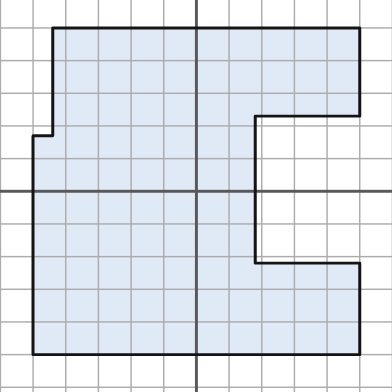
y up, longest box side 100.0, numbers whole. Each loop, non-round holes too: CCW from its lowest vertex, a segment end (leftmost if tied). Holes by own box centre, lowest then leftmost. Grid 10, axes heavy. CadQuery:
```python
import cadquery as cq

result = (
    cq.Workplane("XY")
    .moveTo(-50.0, -50.0)
    .lineTo(50.0, -50.0)
    .lineTo(50.0, -22.0)
    .lineTo(18.0, -22.0)
    .lineTo(18.0, 23.0)
    .lineTo(50.0, 23.0)
    .lineTo(50.0, 50.0)
    .lineTo(-44.0, 50.0)
    .lineTo(-44.0, 17.0)
    .lineTo(-50.0, 17.0)
    .close()
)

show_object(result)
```